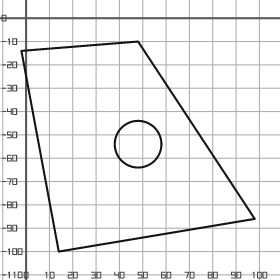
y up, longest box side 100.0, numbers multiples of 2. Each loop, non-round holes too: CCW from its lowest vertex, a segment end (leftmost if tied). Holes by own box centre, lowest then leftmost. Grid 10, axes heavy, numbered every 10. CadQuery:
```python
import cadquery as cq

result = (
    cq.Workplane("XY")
    .moveTo(14.0, -100.0)
    .lineTo(98.0, -86.0)
    .lineTo(48.0, -10.0)
    .lineTo(-2.0, -14.0)
    .close()
    .moveTo(48.0, -54.0)
    .circle(10.0)
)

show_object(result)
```